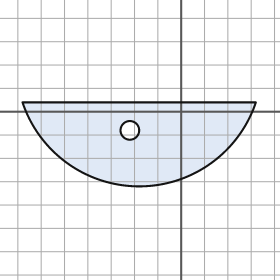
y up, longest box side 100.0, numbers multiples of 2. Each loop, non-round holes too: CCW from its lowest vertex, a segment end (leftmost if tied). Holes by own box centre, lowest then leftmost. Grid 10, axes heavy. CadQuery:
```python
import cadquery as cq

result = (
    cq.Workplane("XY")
    .moveTo(-68.0, 4.0)
    .threePointArc((-18.0, -32.0), (32.0, 4.0))
    .close()
    .moveTo(-22.0, -8.0)
    .circle(4.0)
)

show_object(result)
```